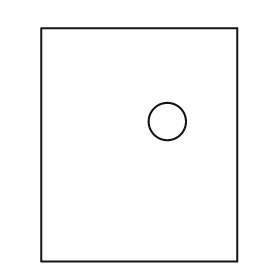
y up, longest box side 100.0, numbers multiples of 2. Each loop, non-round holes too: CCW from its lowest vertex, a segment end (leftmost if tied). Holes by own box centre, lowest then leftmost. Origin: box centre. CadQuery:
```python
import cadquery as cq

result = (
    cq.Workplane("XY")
    .moveTo(-42.0, -50.0)
    .lineTo(42.0, -50.0)
    .lineTo(42.0, 50.0)
    .lineTo(-42.0, 50.0)
    .close()
    .moveTo(12.0, 10.0)
    .circle(8.0)
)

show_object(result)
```